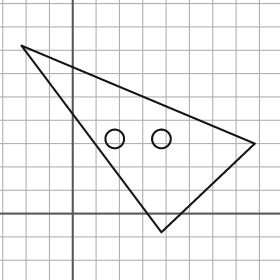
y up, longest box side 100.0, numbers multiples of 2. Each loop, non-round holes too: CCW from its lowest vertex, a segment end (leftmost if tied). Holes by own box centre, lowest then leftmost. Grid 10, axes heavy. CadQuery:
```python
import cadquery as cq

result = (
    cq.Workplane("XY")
    .moveTo(38.0, -8.0)
    .lineTo(78.0, 30.0)
    .lineTo(-22.0, 72.0)
    .close()
    .moveTo(18.0, 32.0)
    .circle(4.0)
    .moveTo(38.0, 32.0)
    .circle(4.0)
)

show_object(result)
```